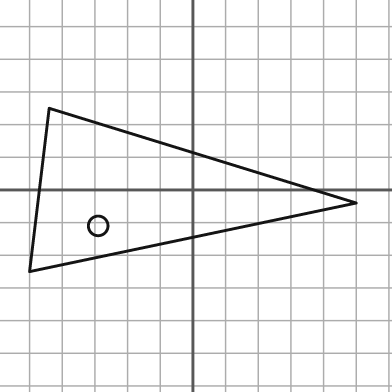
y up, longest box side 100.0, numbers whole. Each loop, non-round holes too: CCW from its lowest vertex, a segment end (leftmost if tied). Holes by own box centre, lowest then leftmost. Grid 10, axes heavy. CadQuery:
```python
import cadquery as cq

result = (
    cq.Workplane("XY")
    .moveTo(-50.0, -25.0)
    .lineTo(50.0, -4.0)
    .lineTo(-44.0, 25.0)
    .close()
    .moveTo(-29.0, -11.0)
    .circle(3.0)
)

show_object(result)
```